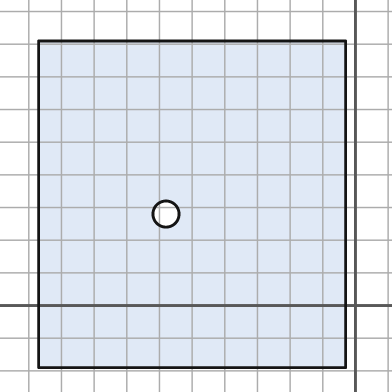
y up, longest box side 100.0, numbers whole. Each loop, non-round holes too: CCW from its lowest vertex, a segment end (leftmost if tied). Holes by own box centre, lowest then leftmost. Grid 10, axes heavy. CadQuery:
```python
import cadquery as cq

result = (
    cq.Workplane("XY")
    .moveTo(-97.0, -19.0)
    .lineTo(-3.0, -19.0)
    .lineTo(-3.0, 81.0)
    .lineTo(-97.0, 81.0)
    .close()
    .moveTo(-58.0, 28.0)
    .circle(4.0)
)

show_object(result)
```